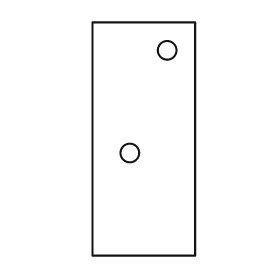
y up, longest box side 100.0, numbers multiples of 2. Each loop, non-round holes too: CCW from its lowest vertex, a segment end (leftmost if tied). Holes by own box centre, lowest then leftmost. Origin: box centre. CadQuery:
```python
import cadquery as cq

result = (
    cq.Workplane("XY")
    .moveTo(-22.0, -50.0)
    .lineTo(22.0, -50.0)
    .lineTo(22.0, 50.0)
    .lineTo(-22.0, 50.0)
    .close()
    .moveTo(-6.0, -6.0)
    .circle(4.0)
    .moveTo(10.0, 38.0)
    .circle(4.0)
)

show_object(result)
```